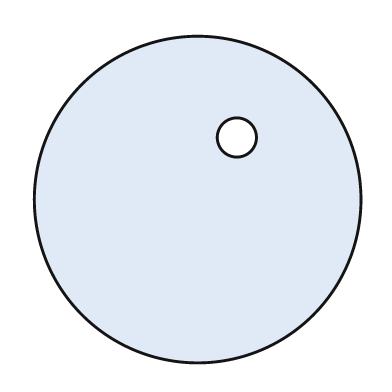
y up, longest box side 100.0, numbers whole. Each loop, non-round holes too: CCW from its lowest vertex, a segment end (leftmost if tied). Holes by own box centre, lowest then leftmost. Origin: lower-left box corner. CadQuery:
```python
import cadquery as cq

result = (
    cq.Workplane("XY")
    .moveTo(50.0, 50.0)
    .circle(50.0)
    .moveTo(62.0, 69.0)
    .circle(6.0)
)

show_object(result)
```